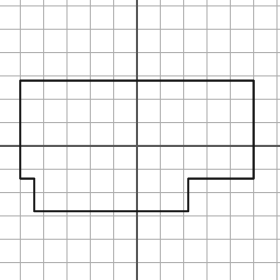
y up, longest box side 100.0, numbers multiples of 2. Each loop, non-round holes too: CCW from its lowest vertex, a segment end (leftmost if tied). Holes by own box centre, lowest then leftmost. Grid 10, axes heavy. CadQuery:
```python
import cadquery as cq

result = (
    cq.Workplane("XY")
    .moveTo(-44.0, -28.0)
    .lineTo(22.0, -28.0)
    .lineTo(22.0, -14.0)
    .lineTo(50.0, -14.0)
    .lineTo(50.0, 28.0)
    .lineTo(-50.0, 28.0)
    .lineTo(-50.0, -14.0)
    .lineTo(-44.0, -14.0)
    .close()
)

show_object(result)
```